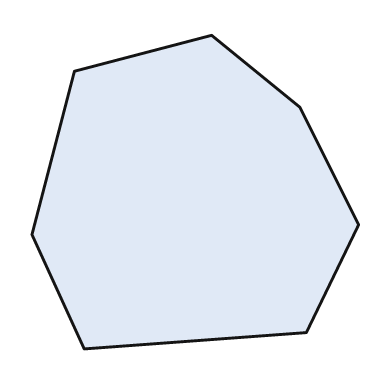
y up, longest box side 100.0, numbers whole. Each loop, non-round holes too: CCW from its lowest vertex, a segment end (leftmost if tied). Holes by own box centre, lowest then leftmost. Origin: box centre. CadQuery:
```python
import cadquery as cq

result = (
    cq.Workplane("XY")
    .moveTo(-34.0, -48.0)
    .lineTo(34.0, -43.0)
    .lineTo(50.0, -10.0)
    .lineTo(32.0, 26.0)
    .lineTo(5.0, 48.0)
    .lineTo(-37.0, 37.0)
    .lineTo(-50.0, -13.0)
    .close()
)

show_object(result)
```